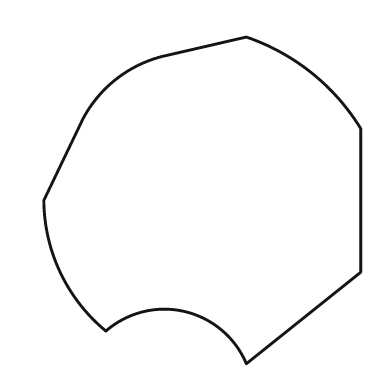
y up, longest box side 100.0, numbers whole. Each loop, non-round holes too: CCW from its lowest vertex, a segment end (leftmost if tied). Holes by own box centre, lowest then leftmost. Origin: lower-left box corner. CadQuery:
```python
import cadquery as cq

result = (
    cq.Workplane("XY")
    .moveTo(62.0, 0.0)
    .lineTo(97.0, 28.0)
    .lineTo(97.0, 72.0)
    .threePointArc((82.0, 89.0), (62.0, 100.0))
    .lineTo(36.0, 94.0)
    .threePointArc((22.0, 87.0), (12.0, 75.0))
    .lineTo(0.0, 50.0)
    .threePointArc((5.0, 28.0), (19.0, 10.0))
    .threePointArc((43.0, 16.0), (62.0, 0.0))
    .close()
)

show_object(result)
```